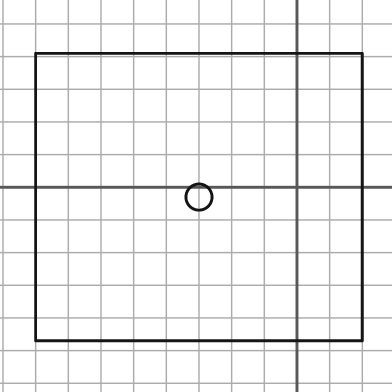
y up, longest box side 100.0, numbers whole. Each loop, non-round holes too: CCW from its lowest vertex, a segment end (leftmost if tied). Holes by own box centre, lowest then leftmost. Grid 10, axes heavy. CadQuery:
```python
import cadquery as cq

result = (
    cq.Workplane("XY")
    .moveTo(-80.0, -47.0)
    .lineTo(20.0, -47.0)
    .lineTo(20.0, 41.0)
    .lineTo(-80.0, 41.0)
    .close()
    .moveTo(-30.0, -3.0)
    .circle(4.0)
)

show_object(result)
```